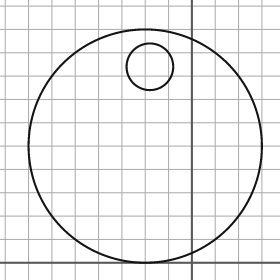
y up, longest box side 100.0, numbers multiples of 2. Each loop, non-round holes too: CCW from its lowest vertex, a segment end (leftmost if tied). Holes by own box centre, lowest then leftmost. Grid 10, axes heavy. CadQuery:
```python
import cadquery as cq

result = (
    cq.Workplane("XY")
    .moveTo(-20.0, 50.0)
    .circle(50.0)
    .moveTo(-18.0, 84.0)
    .circle(10.0)
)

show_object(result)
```